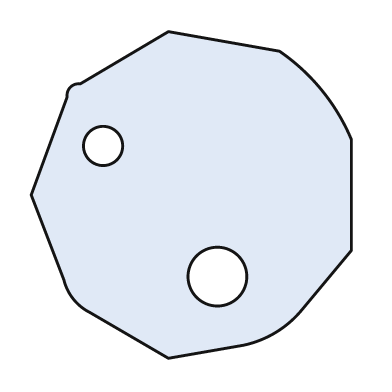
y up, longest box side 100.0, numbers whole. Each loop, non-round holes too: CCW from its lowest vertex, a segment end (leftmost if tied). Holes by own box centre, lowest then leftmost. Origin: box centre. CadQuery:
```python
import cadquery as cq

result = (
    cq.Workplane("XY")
    .moveTo(-7.0, -50.0)
    .lineTo(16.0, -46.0)
    .threePointArc((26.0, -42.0), (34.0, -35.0))
    .lineTo(49.0, -17.0)
    .lineTo(49.0, 17.0)
    .threePointArc((40.0, 32.0), (27.0, 44.0))
    .lineTo(-7.0, 50.0)
    .lineTo(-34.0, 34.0)
    .threePointArc((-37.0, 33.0), (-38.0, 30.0))
    .lineTo(-49.0, 0.0)
    .lineTo(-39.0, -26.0)
    .threePointArc((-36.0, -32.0), (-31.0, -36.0))
    .close()
    .moveTo(8.0, -25.0)
    .circle(9.0)
    .moveTo(-27.0, 15.0)
    .circle(6.0)
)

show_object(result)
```